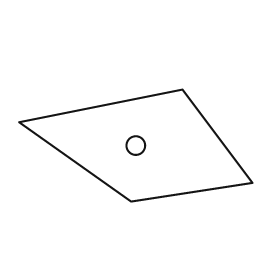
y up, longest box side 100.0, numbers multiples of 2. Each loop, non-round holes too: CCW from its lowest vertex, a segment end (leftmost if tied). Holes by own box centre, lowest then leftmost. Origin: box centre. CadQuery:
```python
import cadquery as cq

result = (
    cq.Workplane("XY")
    .moveTo(-2.0, -24.0)
    .lineTo(50.0, -16.0)
    .lineTo(20.0, 24.0)
    .lineTo(-50.0, 10.0)
    .close()
    .moveTo(0.0, 0.0)
    .circle(4.0)
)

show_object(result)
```